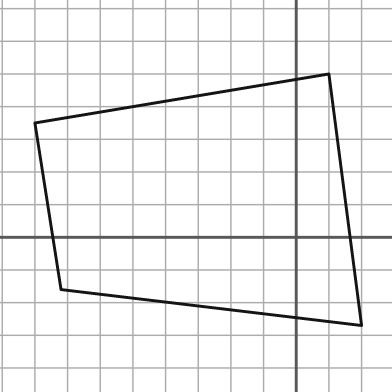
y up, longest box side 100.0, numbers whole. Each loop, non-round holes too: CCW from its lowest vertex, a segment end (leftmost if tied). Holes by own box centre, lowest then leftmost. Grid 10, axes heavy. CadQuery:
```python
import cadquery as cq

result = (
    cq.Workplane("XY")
    .moveTo(20.0, -27.0)
    .lineTo(10.0, 50.0)
    .lineTo(-80.0, 35.0)
    .lineTo(-72.0, -16.0)
    .close()
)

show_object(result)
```